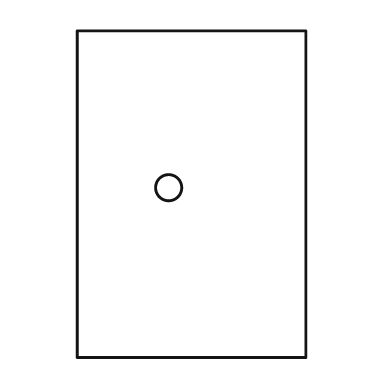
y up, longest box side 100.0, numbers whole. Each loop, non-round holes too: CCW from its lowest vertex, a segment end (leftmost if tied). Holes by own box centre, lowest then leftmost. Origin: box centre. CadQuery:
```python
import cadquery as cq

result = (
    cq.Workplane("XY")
    .moveTo(-35.0, -50.0)
    .lineTo(35.0, -50.0)
    .lineTo(35.0, 50.0)
    .lineTo(-35.0, 50.0)
    .close()
    .moveTo(-7.0, 2.0)
    .circle(4.0)
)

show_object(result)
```